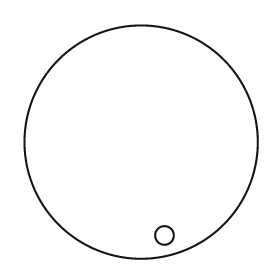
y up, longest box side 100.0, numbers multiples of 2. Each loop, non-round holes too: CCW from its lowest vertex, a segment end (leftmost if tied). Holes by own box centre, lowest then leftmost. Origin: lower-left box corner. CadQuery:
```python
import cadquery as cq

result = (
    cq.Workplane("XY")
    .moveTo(50.0, 50.0)
    .circle(50.0)
    .moveTo(60.0, 10.0)
    .circle(4.0)
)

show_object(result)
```